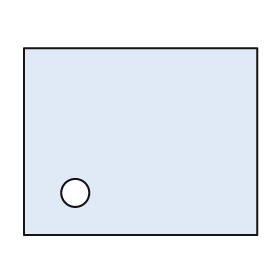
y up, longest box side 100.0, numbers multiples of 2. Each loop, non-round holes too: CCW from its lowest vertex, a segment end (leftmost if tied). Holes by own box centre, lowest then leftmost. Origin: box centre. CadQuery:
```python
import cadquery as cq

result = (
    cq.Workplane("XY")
    .moveTo(-50.0, -40.0)
    .lineTo(50.0, -40.0)
    .lineTo(50.0, 40.0)
    .lineTo(-50.0, 40.0)
    .close()
    .moveTo(-28.0, -22.0)
    .circle(6.0)
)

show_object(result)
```